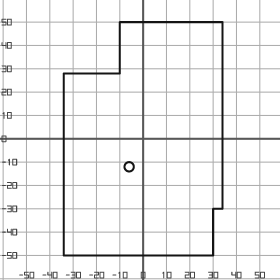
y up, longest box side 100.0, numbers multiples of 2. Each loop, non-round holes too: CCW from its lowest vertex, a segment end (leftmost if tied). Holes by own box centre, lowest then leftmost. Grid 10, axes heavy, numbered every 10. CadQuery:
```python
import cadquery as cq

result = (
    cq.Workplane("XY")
    .moveTo(-34.0, -50.0)
    .lineTo(30.0, -50.0)
    .lineTo(30.0, -30.0)
    .lineTo(34.0, -30.0)
    .lineTo(34.0, 50.0)
    .lineTo(-10.0, 50.0)
    .lineTo(-10.0, 28.0)
    .lineTo(-34.0, 28.0)
    .close()
    .moveTo(-6.0, -12.0)
    .circle(2.0)
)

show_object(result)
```